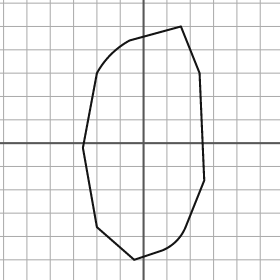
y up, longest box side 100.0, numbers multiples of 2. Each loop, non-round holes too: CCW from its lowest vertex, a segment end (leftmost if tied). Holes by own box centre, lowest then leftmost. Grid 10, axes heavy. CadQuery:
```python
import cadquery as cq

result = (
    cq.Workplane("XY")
    .moveTo(-4.0, -50.0)
    .lineTo(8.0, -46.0)
    .threePointArc((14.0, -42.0), (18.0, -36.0))
    .lineTo(26.0, -16.0)
    .lineTo(24.0, 30.0)
    .lineTo(16.0, 50.0)
    .lineTo(-6.0, 44.0)
    .threePointArc((-14.0, 38.0), (-20.0, 30.0))
    .lineTo(-26.0, -2.0)
    .lineTo(-20.0, -36.0)
    .close()
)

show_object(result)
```